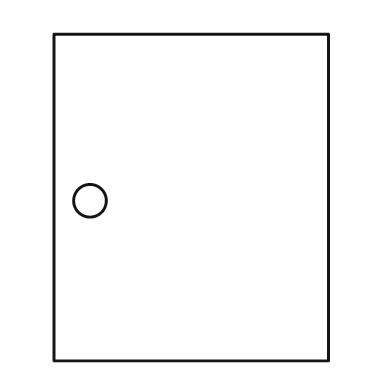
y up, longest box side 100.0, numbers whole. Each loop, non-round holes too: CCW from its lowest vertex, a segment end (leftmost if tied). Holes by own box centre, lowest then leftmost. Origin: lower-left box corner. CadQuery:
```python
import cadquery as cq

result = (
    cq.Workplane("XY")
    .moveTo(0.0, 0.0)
    .lineTo(84.0, 0.0)
    .lineTo(84.0, 100.0)
    .lineTo(0.0, 100.0)
    .close()
    .moveTo(11.0, 49.0)
    .circle(5.0)
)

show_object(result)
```